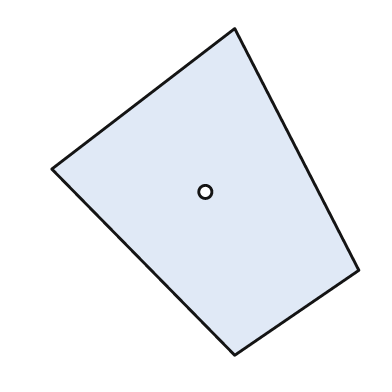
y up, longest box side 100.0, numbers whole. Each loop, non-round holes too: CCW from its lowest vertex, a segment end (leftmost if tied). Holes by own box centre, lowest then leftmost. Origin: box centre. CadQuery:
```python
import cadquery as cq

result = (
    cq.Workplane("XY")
    .moveTo(9.0, -50.0)
    .lineTo(47.0, -24.0)
    .lineTo(9.0, 50.0)
    .lineTo(-47.0, 7.0)
    .close()
    .moveTo(0.0, 0.0)
    .circle(2.0)
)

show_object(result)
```